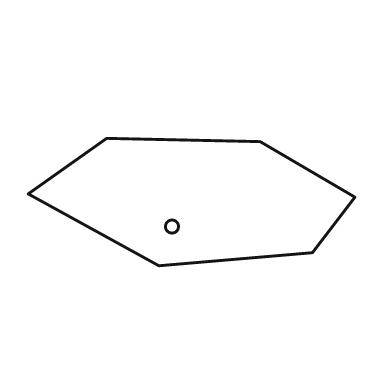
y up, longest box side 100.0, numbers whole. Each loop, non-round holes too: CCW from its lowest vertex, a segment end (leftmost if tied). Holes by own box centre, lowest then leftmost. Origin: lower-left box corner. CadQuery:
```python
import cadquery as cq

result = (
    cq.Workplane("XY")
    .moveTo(40.0, 0.0)
    .lineTo(87.0, 4.0)
    .lineTo(100.0, 21.0)
    .lineTo(71.0, 38.0)
    .lineTo(24.0, 39.0)
    .lineTo(0.0, 22.0)
    .close()
    .moveTo(44.0, 12.0)
    .circle(2.0)
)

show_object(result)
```